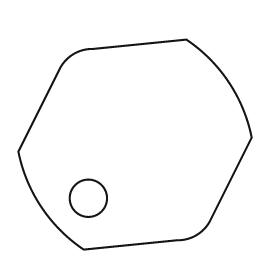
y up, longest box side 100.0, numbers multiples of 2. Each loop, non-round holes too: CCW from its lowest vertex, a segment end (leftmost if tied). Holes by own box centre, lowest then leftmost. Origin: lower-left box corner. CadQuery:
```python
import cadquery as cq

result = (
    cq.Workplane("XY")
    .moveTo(28.0, 0.0)
    .lineTo(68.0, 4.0)
    .threePointArc((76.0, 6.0), (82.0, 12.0))
    .lineTo(100.0, 48.0)
    .threePointArc((90.0, 72.0), (72.0, 90.0))
    .lineTo(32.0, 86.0)
    .threePointArc((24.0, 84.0), (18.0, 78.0))
    .lineTo(0.0, 42.0)
    .threePointArc((10.0, 18.0), (28.0, 0.0))
    .close()
    .moveTo(30.0, 22.0)
    .circle(8.0)
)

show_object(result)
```